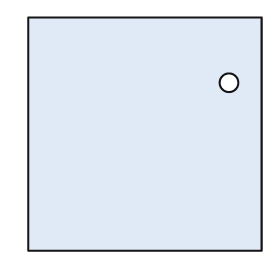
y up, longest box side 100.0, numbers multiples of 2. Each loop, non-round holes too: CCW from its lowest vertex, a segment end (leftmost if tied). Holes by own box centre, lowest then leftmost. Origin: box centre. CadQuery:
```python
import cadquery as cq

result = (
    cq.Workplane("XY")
    .moveTo(-50.0, -50.0)
    .lineTo(50.0, -50.0)
    .lineTo(50.0, 50.0)
    .lineTo(-50.0, 50.0)
    .close()
    .moveTo(36.0, 22.0)
    .circle(4.0)
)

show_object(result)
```